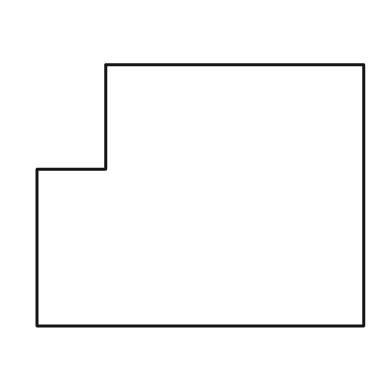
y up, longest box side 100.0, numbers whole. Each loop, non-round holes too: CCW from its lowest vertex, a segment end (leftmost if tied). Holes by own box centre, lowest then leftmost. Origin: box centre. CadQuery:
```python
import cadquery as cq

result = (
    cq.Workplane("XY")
    .moveTo(-50.0, -40.0)
    .lineTo(50.0, -40.0)
    .lineTo(50.0, 40.0)
    .lineTo(-29.0, 40.0)
    .lineTo(-29.0, 8.0)
    .lineTo(-50.0, 8.0)
    .close()
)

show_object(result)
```